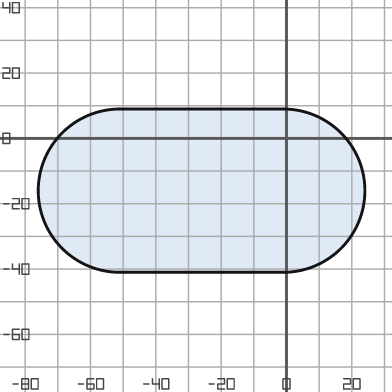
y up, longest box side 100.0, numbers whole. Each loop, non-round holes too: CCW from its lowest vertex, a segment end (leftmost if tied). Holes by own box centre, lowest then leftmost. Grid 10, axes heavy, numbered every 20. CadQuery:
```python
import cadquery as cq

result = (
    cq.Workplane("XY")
    .moveTo(-51.0, -41.0)
    .lineTo(-1.0, -41.0)
    .threePointArc((24.0, -16.0), (-1.0, 9.0))
    .lineTo(-51.0, 9.0)
    .threePointArc((-76.0, -16.0), (-51.0, -41.0))
    .close()
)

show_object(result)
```